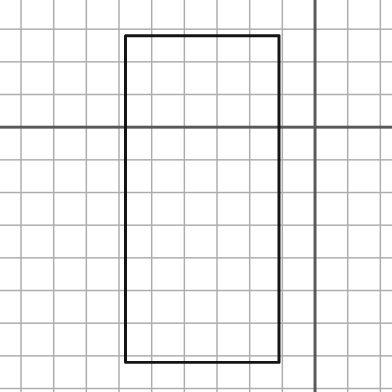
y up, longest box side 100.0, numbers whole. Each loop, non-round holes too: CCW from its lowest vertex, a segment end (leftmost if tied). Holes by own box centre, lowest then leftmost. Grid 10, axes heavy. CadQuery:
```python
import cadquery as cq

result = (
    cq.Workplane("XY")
    .moveTo(-58.0, -72.0)
    .lineTo(-11.0, -72.0)
    .lineTo(-11.0, 28.0)
    .lineTo(-58.0, 28.0)
    .close()
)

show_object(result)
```